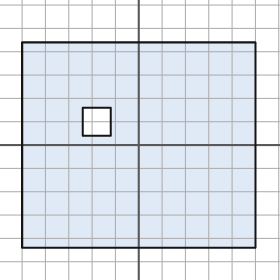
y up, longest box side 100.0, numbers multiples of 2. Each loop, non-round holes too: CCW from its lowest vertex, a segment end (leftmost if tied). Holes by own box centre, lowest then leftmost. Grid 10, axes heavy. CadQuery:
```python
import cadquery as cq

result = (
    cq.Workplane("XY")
    .moveTo(-50.0, -44.0)
    .lineTo(50.0, -44.0)
    .lineTo(50.0, 44.0)
    .lineTo(-50.0, 44.0)
    .close()
    .moveTo(-24.0, 4.0)
    .lineTo(-12.0, 4.0)
    .lineTo(-12.0, 16.0)
    .lineTo(-24.0, 16.0)
    .close()
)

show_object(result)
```